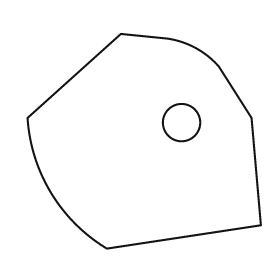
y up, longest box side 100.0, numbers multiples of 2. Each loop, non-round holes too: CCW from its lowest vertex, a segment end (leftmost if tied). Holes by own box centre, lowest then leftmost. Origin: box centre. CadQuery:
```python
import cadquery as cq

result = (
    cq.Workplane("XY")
    .moveTo(-16.0, -46.0)
    .lineTo(50.0, -36.0)
    .lineTo(46.0, 10.0)
    .lineTo(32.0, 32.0)
    .threePointArc((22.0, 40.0), (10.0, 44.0))
    .lineTo(-10.0, 46.0)
    .lineTo(-50.0, 10.0)
    .threePointArc((-40.0, -22.0), (-16.0, -46.0))
    .close()
    .moveTo(16.0, 8.0)
    .circle(8.0)
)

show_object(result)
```